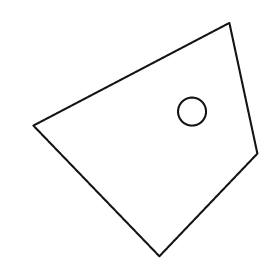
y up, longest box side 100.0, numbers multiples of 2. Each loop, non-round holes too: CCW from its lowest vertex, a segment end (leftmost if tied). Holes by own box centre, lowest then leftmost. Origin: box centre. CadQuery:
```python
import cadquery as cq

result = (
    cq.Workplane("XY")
    .moveTo(6.0, -50.0)
    .lineTo(48.0, -6.0)
    .lineTo(36.0, 50.0)
    .lineTo(-48.0, 6.0)
    .close()
    .moveTo(20.0, 12.0)
    .circle(6.0)
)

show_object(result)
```